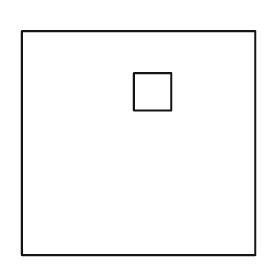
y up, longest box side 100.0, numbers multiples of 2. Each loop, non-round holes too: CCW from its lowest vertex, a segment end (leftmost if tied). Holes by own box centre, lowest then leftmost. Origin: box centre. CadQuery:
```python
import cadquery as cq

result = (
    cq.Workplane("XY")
    .moveTo(-50.0, -48.0)
    .lineTo(50.0, -48.0)
    .lineTo(50.0, 48.0)
    .lineTo(-50.0, 48.0)
    .close()
    .moveTo(-2.0, 14.0)
    .lineTo(14.0, 14.0)
    .lineTo(14.0, 30.0)
    .lineTo(-2.0, 30.0)
    .close()
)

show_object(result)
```